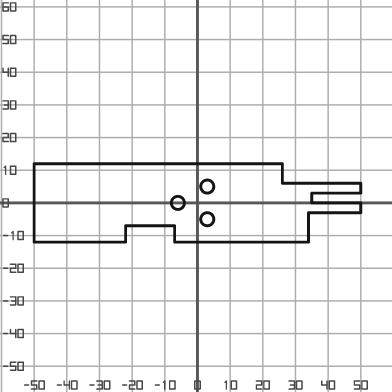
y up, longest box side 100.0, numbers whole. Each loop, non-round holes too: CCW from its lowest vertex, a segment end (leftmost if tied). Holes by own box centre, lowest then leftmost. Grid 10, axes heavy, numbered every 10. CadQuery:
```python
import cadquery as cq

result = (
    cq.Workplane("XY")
    .moveTo(-50.0, -12.0)
    .lineTo(-22.0, -12.0)
    .lineTo(-22.0, -7.0)
    .lineTo(-7.0, -7.0)
    .lineTo(-7.0, -12.0)
    .lineTo(34.0, -12.0)
    .lineTo(34.0, -3.0)
    .lineTo(50.0, -3.0)
    .lineTo(50.0, 0.0)
    .lineTo(35.0, 0.0)
    .lineTo(35.0, 3.0)
    .lineTo(50.0, 3.0)
    .lineTo(50.0, 6.0)
    .lineTo(26.0, 6.0)
    .lineTo(26.0, 12.0)
    .lineTo(-50.0, 12.0)
    .close()
    .moveTo(3.0, -5.0)
    .circle(2.0)
    .moveTo(-6.0, 0.0)
    .circle(2.0)
    .moveTo(3.0, 5.0)
    .circle(2.0)
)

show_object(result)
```